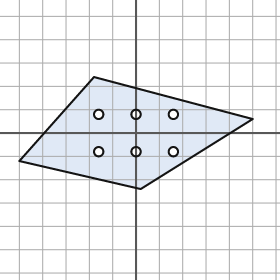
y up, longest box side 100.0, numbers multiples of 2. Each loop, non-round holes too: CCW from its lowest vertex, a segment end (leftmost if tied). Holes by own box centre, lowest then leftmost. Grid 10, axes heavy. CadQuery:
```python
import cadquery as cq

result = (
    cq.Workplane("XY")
    .moveTo(2.0, -24.0)
    .lineTo(50.0, 6.0)
    .lineTo(-18.0, 24.0)
    .lineTo(-50.0, -12.0)
    .close()
    .moveTo(-16.0, -8.0)
    .circle(2.0)
    .moveTo(0.0, -8.0)
    .circle(2.0)
    .moveTo(16.0, -8.0)
    .circle(2.0)
    .moveTo(-16.0, 8.0)
    .circle(2.0)
    .moveTo(0.0, 8.0)
    .circle(2.0)
    .moveTo(16.0, 8.0)
    .circle(2.0)
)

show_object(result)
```